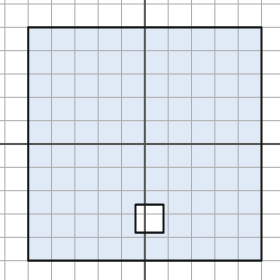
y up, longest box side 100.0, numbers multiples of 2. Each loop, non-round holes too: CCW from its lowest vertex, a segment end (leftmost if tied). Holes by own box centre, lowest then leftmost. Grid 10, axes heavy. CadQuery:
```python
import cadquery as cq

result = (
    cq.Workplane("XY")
    .moveTo(-50.0, -50.0)
    .lineTo(50.0, -50.0)
    .lineTo(50.0, 50.0)
    .lineTo(-50.0, 50.0)
    .close()
    .moveTo(-4.0, -38.0)
    .lineTo(8.0, -38.0)
    .lineTo(8.0, -26.0)
    .lineTo(-4.0, -26.0)
    .close()
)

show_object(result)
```